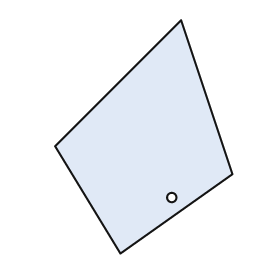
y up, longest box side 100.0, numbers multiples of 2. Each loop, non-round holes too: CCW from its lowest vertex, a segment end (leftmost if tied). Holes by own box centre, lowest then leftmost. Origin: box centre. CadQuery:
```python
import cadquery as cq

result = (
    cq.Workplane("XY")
    .moveTo(-10.0, -50.0)
    .lineTo(38.0, -16.0)
    .lineTo(16.0, 50.0)
    .lineTo(-38.0, -4.0)
    .close()
    .moveTo(12.0, -26.0)
    .circle(2.0)
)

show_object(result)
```